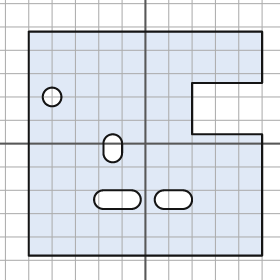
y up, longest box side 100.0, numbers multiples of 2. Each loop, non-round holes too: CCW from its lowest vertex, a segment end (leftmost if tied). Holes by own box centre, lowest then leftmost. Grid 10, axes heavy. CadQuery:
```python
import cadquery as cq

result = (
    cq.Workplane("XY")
    .moveTo(-50.0, -48.0)
    .lineTo(50.0, -48.0)
    .lineTo(50.0, 4.0)
    .lineTo(20.0, 4.0)
    .lineTo(20.0, 26.0)
    .lineTo(50.0, 26.0)
    .lineTo(50.0, 48.0)
    .lineTo(-50.0, 48.0)
    .close()
    .moveTo(-18.0, -28.0)
    .lineTo(-6.0, -28.0)
    .threePointArc((-2.0, -24.0), (-6.0, -20.0))
    .lineTo(-18.0, -20.0)
    .threePointArc((-22.0, -24.0), (-18.0, -28.0))
    .close()
    .moveTo(8.0, -28.0)
    .lineTo(16.0, -28.0)
    .threePointArc((20.0, -24.0), (16.0, -20.0))
    .lineTo(8.0, -20.0)
    .threePointArc((4.0, -24.0), (8.0, -28.0))
    .close()
    .moveTo(-18.0, -4.0)
    .threePointArc((-14.0, -8.0), (-10.0, -4.0))
    .lineTo(-10.0, 0.0)
    .threePointArc((-14.0, 4.0), (-18.0, 0.0))
    .close()
    .moveTo(-40.0, 20.0)
    .circle(4.0)
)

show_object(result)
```